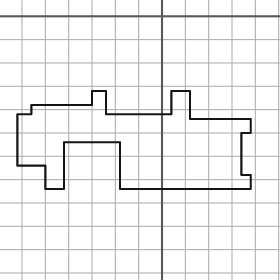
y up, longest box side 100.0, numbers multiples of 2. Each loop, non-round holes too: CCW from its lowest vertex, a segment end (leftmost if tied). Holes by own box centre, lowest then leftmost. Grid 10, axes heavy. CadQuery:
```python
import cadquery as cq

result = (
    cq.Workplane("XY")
    .moveTo(-50.0, -74.0)
    .lineTo(-42.0, -74.0)
    .lineTo(-42.0, -54.0)
    .lineTo(-18.0, -54.0)
    .lineTo(-18.0, -74.0)
    .lineTo(38.0, -74.0)
    .lineTo(38.0, -68.0)
    .lineTo(34.0, -68.0)
    .lineTo(34.0, -50.0)
    .lineTo(38.0, -50.0)
    .lineTo(38.0, -44.0)
    .lineTo(12.0, -44.0)
    .lineTo(12.0, -32.0)
    .lineTo(4.0, -32.0)
    .lineTo(4.0, -42.0)
    .lineTo(-24.0, -42.0)
    .lineTo(-24.0, -32.0)
    .lineTo(-30.0, -32.0)
    .lineTo(-30.0, -38.0)
    .lineTo(-56.0, -38.0)
    .lineTo(-56.0, -42.0)
    .lineTo(-62.0, -42.0)
    .lineTo(-62.0, -64.0)
    .lineTo(-50.0, -64.0)
    .close()
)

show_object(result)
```